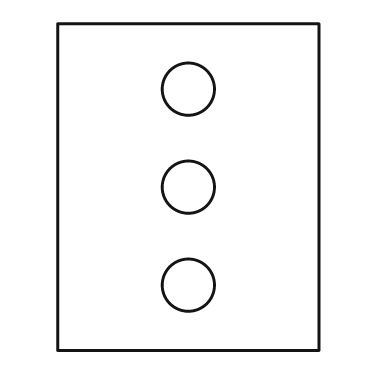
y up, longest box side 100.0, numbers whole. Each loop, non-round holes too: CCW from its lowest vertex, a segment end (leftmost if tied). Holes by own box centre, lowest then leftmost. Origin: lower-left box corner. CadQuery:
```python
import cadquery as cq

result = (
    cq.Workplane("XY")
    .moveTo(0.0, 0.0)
    .lineTo(80.0, 0.0)
    .lineTo(80.0, 100.0)
    .lineTo(0.0, 100.0)
    .close()
    .moveTo(40.0, 20.0)
    .circle(8.0)
    .moveTo(40.0, 50.0)
    .circle(8.0)
    .moveTo(40.0, 80.0)
    .circle(8.0)
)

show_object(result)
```